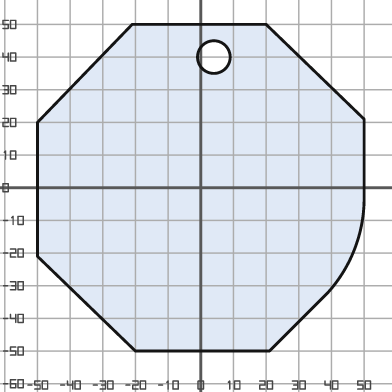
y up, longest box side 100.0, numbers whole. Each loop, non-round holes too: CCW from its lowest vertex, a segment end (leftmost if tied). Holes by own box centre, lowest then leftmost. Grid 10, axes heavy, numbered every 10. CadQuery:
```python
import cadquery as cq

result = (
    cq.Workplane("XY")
    .moveTo(-20.0, -50.0)
    .lineTo(21.0, -50.0)
    .lineTo(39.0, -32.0)
    .threePointArc((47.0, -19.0), (50.0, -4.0))
    .lineTo(50.0, 21.0)
    .lineTo(20.0, 50.0)
    .lineTo(-21.0, 50.0)
    .lineTo(-50.0, 20.0)
    .lineTo(-50.0, -21.0)
    .close()
    .moveTo(4.0, 40.0)
    .circle(5.0)
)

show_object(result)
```